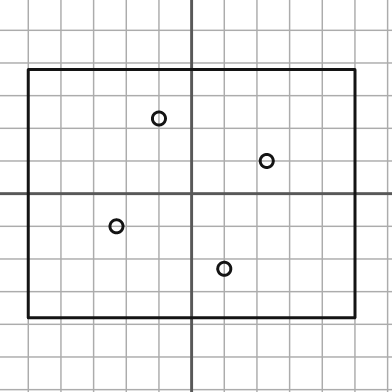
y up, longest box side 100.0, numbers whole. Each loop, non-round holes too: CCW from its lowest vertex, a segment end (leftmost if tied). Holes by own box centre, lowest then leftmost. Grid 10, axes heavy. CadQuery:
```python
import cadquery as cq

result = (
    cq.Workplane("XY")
    .moveTo(-50.0, -38.0)
    .lineTo(50.0, -38.0)
    .lineTo(50.0, 38.0)
    .lineTo(-50.0, 38.0)
    .close()
    .moveTo(10.0, -23.0)
    .circle(2.0)
    .moveTo(-23.0, -10.0)
    .circle(2.0)
    .moveTo(23.0, 10.0)
    .circle(2.0)
    .moveTo(-10.0, 23.0)
    .circle(2.0)
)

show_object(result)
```